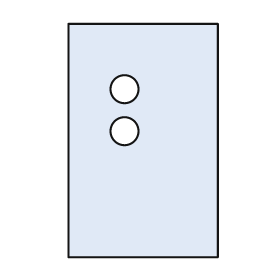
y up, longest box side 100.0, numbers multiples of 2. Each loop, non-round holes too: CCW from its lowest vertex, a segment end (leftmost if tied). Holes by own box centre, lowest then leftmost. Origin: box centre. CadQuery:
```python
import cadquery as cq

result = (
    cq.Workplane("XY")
    .moveTo(-32.0, -50.0)
    .lineTo(32.0, -50.0)
    .lineTo(32.0, 50.0)
    .lineTo(-32.0, 50.0)
    .close()
    .moveTo(-8.0, 4.0)
    .circle(6.0)
    .moveTo(-8.0, 22.0)
    .circle(6.0)
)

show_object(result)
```